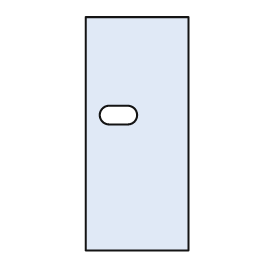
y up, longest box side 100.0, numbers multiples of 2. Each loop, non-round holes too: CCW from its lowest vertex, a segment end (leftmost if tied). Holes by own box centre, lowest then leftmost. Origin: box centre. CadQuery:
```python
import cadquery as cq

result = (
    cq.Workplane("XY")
    .moveTo(-22.0, -50.0)
    .lineTo(22.0, -50.0)
    .lineTo(22.0, 50.0)
    .lineTo(-22.0, 50.0)
    .close()
    .moveTo(-12.0, 4.0)
    .lineTo(-4.0, 4.0)
    .threePointArc((0.0, 8.0), (-4.0, 12.0))
    .lineTo(-12.0, 12.0)
    .threePointArc((-16.0, 8.0), (-12.0, 4.0))
    .close()
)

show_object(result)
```